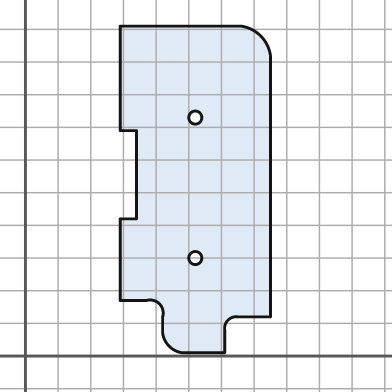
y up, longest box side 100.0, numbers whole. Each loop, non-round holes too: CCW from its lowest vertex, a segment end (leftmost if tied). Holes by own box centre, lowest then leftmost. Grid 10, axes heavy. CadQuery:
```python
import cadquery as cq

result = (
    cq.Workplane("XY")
    .moveTo(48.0, 1.0)
    .lineTo(61.0, 1.0)
    .lineTo(61.0, 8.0)
    .threePointArc((62.0, 11.0), (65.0, 12.0))
    .lineTo(75.0, 12.0)
    .lineTo(75.0, 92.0)
    .threePointArc((72.0, 98.0), (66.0, 101.0))
    .lineTo(29.0, 101.0)
    .lineTo(29.0, 69.0)
    .lineTo(34.0, 69.0)
    .lineTo(34.0, 42.0)
    .lineTo(29.0, 42.0)
    .lineTo(29.0, 17.0)
    .lineTo(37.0, 17.0)
    .threePointArc((41.0, 16.0), (42.0, 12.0))
    .lineTo(42.0, 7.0)
    .threePointArc((44.0, 3.0), (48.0, 1.0))
    .close()
    .moveTo(52.0, 30.0)
    .circle(2.0)
    .moveTo(52.0, 73.0)
    .circle(2.0)
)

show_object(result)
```